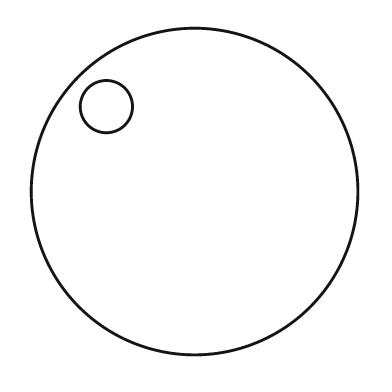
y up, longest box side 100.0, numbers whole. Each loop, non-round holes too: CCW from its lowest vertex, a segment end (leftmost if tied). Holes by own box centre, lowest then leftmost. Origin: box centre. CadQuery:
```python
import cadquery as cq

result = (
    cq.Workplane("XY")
    .moveTo(0.0, 0.0)
    .circle(50.0)
    .moveTo(-27.0, 26.0)
    .circle(8.0)
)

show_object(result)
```